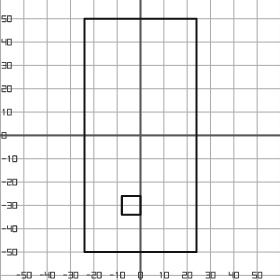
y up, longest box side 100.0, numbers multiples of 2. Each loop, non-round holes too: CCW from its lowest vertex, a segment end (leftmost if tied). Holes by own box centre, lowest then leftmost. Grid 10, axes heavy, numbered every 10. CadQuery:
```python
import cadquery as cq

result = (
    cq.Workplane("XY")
    .moveTo(-24.0, -50.0)
    .lineTo(24.0, -50.0)
    .lineTo(24.0, 50.0)
    .lineTo(-24.0, 50.0)
    .close()
    .moveTo(-8.0, -34.0)
    .lineTo(0.0, -34.0)
    .lineTo(0.0, -26.0)
    .lineTo(-8.0, -26.0)
    .close()
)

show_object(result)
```